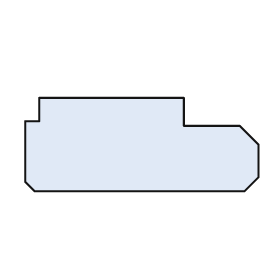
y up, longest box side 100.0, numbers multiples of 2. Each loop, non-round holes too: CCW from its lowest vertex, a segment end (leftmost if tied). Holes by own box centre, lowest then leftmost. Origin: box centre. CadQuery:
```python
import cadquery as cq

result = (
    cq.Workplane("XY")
    .moveTo(-46.0, -20.0)
    .lineTo(44.0, -20.0)
    .lineTo(50.0, -14.0)
    .lineTo(50.0, 0.0)
    .lineTo(42.0, 8.0)
    .lineTo(18.0, 8.0)
    .lineTo(18.0, 20.0)
    .lineTo(-44.0, 20.0)
    .lineTo(-44.0, 10.0)
    .lineTo(-50.0, 10.0)
    .lineTo(-50.0, -16.0)
    .close()
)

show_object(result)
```